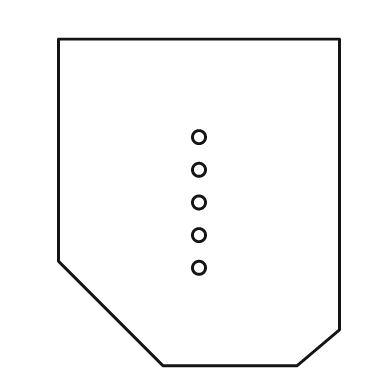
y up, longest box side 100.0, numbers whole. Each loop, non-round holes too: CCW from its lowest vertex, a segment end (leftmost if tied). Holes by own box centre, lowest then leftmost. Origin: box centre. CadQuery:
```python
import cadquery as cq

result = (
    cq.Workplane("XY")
    .moveTo(-11.0, -50.0)
    .lineTo(30.0, -50.0)
    .lineTo(43.0, -39.0)
    .lineTo(43.0, 50.0)
    .lineTo(-43.0, 50.0)
    .lineTo(-43.0, -18.0)
    .close()
    .moveTo(0.0, -20.0)
    .circle(2.0)
    .moveTo(0.0, -10.0)
    .circle(2.0)
    .moveTo(0.0, 0.0)
    .circle(2.0)
    .moveTo(0.0, 10.0)
    .circle(2.0)
    .moveTo(0.0, 20.0)
    .circle(2.0)
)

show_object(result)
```